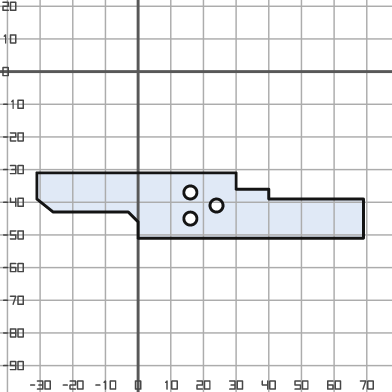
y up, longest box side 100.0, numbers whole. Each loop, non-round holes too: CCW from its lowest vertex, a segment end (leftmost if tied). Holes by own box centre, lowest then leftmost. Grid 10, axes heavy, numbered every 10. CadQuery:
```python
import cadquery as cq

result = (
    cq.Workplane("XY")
    .moveTo(0.0, -51.0)
    .lineTo(69.0, -51.0)
    .lineTo(69.0, -39.0)
    .lineTo(40.0, -39.0)
    .lineTo(40.0, -36.0)
    .lineTo(30.0, -36.0)
    .lineTo(30.0, -31.0)
    .lineTo(-31.0, -31.0)
    .lineTo(-31.0, -39.0)
    .lineTo(-26.0, -43.0)
    .lineTo(-3.0, -43.0)
    .lineTo(0.0, -46.0)
    .close()
    .moveTo(16.0, -45.0)
    .circle(2.0)
    .moveTo(24.0, -41.0)
    .circle(2.0)
    .moveTo(16.0, -37.0)
    .circle(2.0)
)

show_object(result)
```